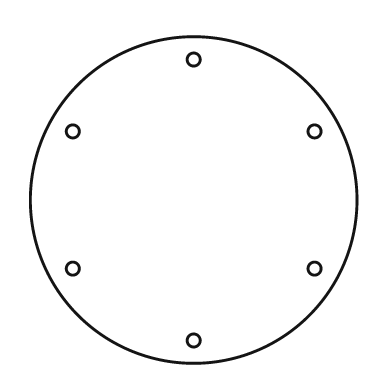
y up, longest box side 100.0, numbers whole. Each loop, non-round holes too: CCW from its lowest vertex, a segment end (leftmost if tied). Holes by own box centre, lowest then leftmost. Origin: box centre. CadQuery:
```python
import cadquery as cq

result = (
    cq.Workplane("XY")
    .moveTo(0.0, 0.0)
    .circle(50.0)
    .moveTo(0.0, -43.0)
    .circle(2.0)
    .moveTo(-37.0, -21.0)
    .circle(2.0)
    .moveTo(37.0, -21.0)
    .circle(2.0)
    .moveTo(-37.0, 21.0)
    .circle(2.0)
    .moveTo(37.0, 21.0)
    .circle(2.0)
    .moveTo(0.0, 43.0)
    .circle(2.0)
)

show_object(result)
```